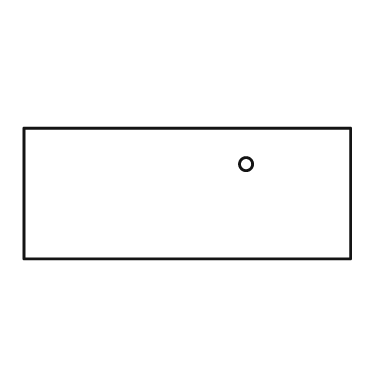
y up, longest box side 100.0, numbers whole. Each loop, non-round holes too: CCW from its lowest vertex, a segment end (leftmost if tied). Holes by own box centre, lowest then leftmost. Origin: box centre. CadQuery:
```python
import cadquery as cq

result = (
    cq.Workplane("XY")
    .moveTo(-50.0, -20.0)
    .lineTo(50.0, -20.0)
    .lineTo(50.0, 20.0)
    .lineTo(-50.0, 20.0)
    .close()
    .moveTo(18.0, 9.0)
    .circle(2.0)
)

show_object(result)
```